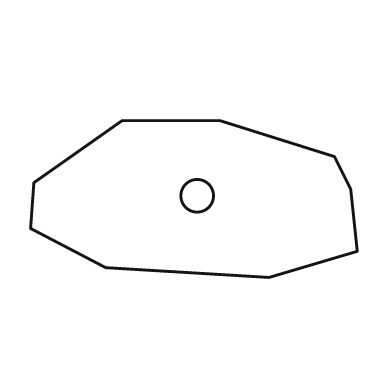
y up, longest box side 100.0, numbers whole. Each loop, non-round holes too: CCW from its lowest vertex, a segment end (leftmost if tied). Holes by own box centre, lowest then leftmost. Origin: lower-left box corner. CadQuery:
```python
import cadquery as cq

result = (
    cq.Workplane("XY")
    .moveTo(73.0, 0.0)
    .lineTo(100.0, 8.0)
    .lineTo(98.0, 27.0)
    .lineTo(93.0, 37.0)
    .lineTo(58.0, 48.0)
    .lineTo(28.0, 48.0)
    .lineTo(1.0, 29.0)
    .lineTo(0.0, 15.0)
    .lineTo(23.0, 3.0)
    .close()
    .moveTo(51.0, 25.0)
    .circle(5.0)
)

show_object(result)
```